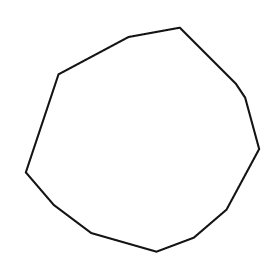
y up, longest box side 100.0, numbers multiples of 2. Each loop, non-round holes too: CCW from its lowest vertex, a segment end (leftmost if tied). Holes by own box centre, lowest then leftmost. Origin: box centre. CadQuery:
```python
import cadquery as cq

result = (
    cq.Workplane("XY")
    .moveTo(6.0, -48.0)
    .lineTo(22.0, -42.0)
    .lineTo(36.0, -30.0)
    .lineTo(50.0, -4.0)
    .lineTo(44.0, 18.0)
    .lineTo(40.0, 24.0)
    .lineTo(16.0, 48.0)
    .lineTo(-6.0, 44.0)
    .lineTo(-36.0, 28.0)
    .lineTo(-50.0, -14.0)
    .lineTo(-38.0, -28.0)
    .lineTo(-22.0, -40.0)
    .close()
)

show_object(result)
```